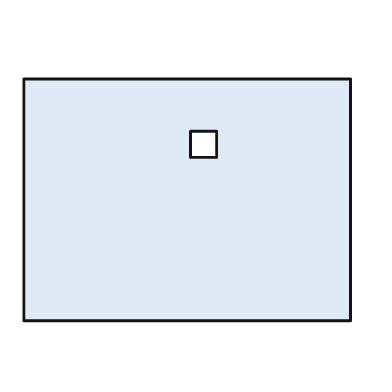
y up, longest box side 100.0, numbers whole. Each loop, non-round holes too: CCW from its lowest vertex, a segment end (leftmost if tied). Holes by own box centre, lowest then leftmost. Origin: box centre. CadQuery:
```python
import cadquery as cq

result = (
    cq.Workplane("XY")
    .moveTo(-50.0, -37.0)
    .lineTo(50.0, -37.0)
    .lineTo(50.0, 37.0)
    .lineTo(-50.0, 37.0)
    .close()
    .moveTo(1.0, 13.0)
    .lineTo(9.0, 13.0)
    .lineTo(9.0, 21.0)
    .lineTo(1.0, 21.0)
    .close()
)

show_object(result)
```